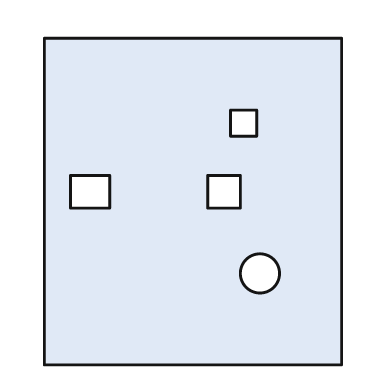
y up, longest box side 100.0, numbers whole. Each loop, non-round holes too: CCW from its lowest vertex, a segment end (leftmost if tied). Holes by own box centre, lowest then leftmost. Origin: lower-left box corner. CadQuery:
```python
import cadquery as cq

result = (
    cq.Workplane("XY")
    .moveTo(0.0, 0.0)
    .lineTo(91.0, 0.0)
    .lineTo(91.0, 100.0)
    .lineTo(0.0, 100.0)
    .close()
    .moveTo(66.0, 28.0)
    .circle(6.0)
    .moveTo(8.0, 48.0)
    .lineTo(20.0, 48.0)
    .lineTo(20.0, 58.0)
    .lineTo(8.0, 58.0)
    .close()
    .moveTo(50.0, 48.0)
    .lineTo(60.0, 48.0)
    .lineTo(60.0, 58.0)
    .lineTo(50.0, 58.0)
    .close()
    .moveTo(57.0, 70.0)
    .lineTo(65.0, 70.0)
    .lineTo(65.0, 78.0)
    .lineTo(57.0, 78.0)
    .close()
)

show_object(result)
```